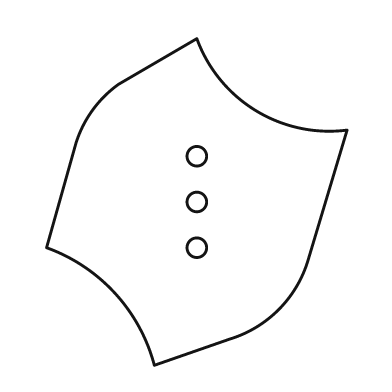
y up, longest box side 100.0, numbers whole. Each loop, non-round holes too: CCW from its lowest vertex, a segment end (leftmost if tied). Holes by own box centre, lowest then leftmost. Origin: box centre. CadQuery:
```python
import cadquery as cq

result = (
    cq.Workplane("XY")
    .moveTo(-13.0, -50.0)
    .lineTo(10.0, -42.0)
    .threePointArc((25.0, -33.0), (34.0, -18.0))
    .lineTo(46.0, 22.0)
    .threePointArc((18.0, 28.0), (0.0, 50.0))
    .lineTo(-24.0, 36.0)
    .threePointArc((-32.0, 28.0), (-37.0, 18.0))
    .lineTo(-46.0, -14.0)
    .threePointArc((-25.0, -28.0), (-13.0, -50.0))
    .close()
    .moveTo(0.0, -14.0)
    .circle(3.0)
    .moveTo(0.0, 0.0)
    .circle(3.0)
    .moveTo(0.0, 14.0)
    .circle(3.0)
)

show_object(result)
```